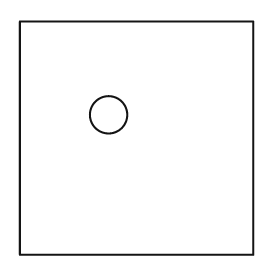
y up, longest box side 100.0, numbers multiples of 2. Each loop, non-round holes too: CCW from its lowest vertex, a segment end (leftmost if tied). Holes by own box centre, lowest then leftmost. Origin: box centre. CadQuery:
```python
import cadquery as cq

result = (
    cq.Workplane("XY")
    .moveTo(-50.0, -50.0)
    .lineTo(50.0, -50.0)
    .lineTo(50.0, 50.0)
    .lineTo(-50.0, 50.0)
    .close()
    .moveTo(-12.0, 10.0)
    .circle(8.0)
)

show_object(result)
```